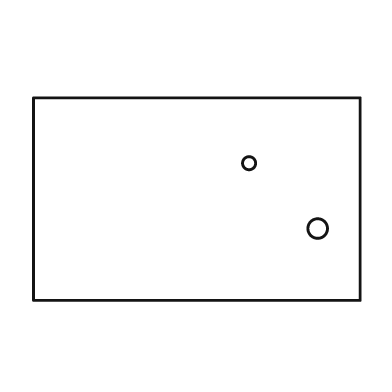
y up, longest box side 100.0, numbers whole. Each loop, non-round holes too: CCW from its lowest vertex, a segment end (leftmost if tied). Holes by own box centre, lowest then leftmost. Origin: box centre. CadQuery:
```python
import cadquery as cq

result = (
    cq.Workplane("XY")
    .moveTo(-50.0, -31.0)
    .lineTo(50.0, -31.0)
    .lineTo(50.0, 31.0)
    .lineTo(-50.0, 31.0)
    .close()
    .moveTo(37.0, -9.0)
    .circle(3.0)
    .moveTo(16.0, 11.0)
    .circle(2.0)
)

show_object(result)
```